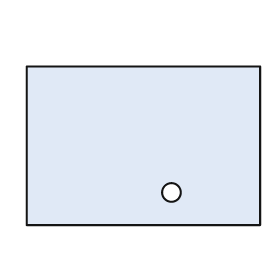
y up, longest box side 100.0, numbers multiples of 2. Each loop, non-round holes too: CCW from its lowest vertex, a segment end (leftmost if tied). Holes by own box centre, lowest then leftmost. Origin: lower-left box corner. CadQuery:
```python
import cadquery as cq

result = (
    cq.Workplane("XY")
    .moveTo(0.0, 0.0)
    .lineTo(100.0, 0.0)
    .lineTo(100.0, 68.0)
    .lineTo(0.0, 68.0)
    .close()
    .moveTo(62.0, 14.0)
    .circle(4.0)
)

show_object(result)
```